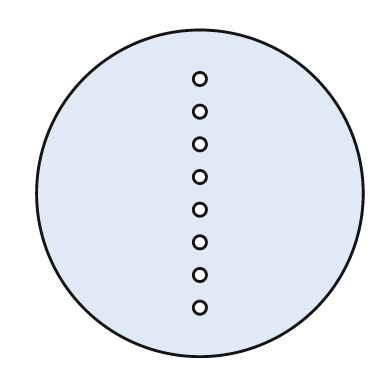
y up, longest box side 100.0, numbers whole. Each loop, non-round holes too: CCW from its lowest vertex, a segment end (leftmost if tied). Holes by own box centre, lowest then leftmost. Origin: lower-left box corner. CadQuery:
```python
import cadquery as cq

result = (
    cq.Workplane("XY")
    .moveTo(50.0, 50.0)
    .circle(50.0)
    .moveTo(50.0, 15.0)
    .circle(2.0)
    .moveTo(50.0, 25.0)
    .circle(2.0)
    .moveTo(50.0, 35.0)
    .circle(2.0)
    .moveTo(50.0, 45.0)
    .circle(2.0)
    .moveTo(50.0, 55.0)
    .circle(2.0)
    .moveTo(50.0, 65.0)
    .circle(2.0)
    .moveTo(50.0, 75.0)
    .circle(2.0)
    .moveTo(50.0, 85.0)
    .circle(2.0)
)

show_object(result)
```